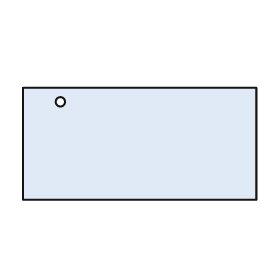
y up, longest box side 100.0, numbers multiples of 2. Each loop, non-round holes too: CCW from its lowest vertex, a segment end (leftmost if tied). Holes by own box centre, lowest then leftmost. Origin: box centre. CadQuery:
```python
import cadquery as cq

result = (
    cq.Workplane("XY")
    .moveTo(-50.0, -24.0)
    .lineTo(50.0, -24.0)
    .lineTo(50.0, 24.0)
    .lineTo(-50.0, 24.0)
    .close()
    .moveTo(-34.0, 18.0)
    .circle(2.0)
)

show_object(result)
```